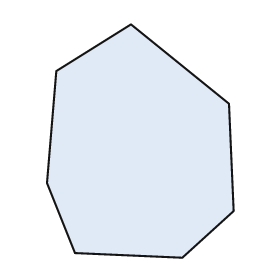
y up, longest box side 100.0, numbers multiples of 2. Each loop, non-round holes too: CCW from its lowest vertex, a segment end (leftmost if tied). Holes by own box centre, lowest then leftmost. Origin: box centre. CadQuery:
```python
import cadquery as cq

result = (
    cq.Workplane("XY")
    .moveTo(18.0, -50.0)
    .lineTo(40.0, -30.0)
    .lineTo(38.0, 16.0)
    .lineTo(-4.0, 50.0)
    .lineTo(-36.0, 30.0)
    .lineTo(-40.0, -18.0)
    .lineTo(-28.0, -48.0)
    .close()
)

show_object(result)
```